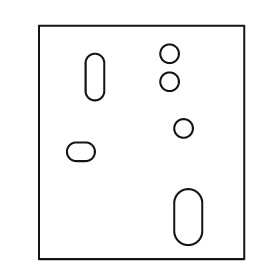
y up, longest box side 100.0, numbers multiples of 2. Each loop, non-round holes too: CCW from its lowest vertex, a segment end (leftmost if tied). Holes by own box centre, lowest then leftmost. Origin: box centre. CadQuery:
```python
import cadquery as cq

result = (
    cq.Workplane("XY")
    .moveTo(-44.0, -50.0)
    .lineTo(44.0, -50.0)
    .lineTo(44.0, 50.0)
    .lineTo(-44.0, 50.0)
    .close()
    .moveTo(14.0, -38.0)
    .threePointArc((20.0, -44.0), (26.0, -38.0))
    .lineTo(26.0, -26.0)
    .threePointArc((20.0, -20.0), (14.0, -26.0))
    .close()
    .moveTo(-28.0, -8.0)
    .lineTo(-24.0, -8.0)
    .threePointArc((-20.0, -4.0), (-24.0, 0.0))
    .lineTo(-28.0, 0.0)
    .threePointArc((-32.0, -4.0), (-28.0, -8.0))
    .close()
    .moveTo(18.0, 6.0)
    .circle(4.0)
    .moveTo(12.0, 26.0)
    .circle(4.0)
    .moveTo(-24.0, 22.0)
    .threePointArc((-20.0, 18.0), (-16.0, 22.0))
    .lineTo(-16.0, 34.0)
    .threePointArc((-20.0, 38.0), (-24.0, 34.0))
    .close()
    .moveTo(12.0, 38.0)
    .circle(4.0)
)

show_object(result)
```